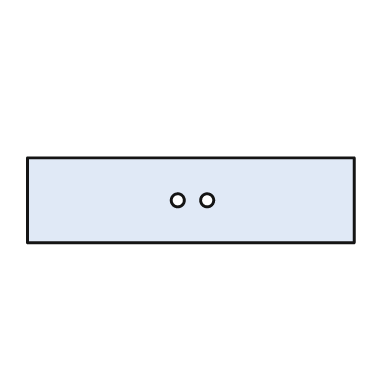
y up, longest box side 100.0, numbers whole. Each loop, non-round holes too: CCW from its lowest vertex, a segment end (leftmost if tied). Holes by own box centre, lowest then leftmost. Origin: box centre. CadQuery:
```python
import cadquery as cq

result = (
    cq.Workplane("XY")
    .moveTo(-50.0, -13.0)
    .lineTo(50.0, -13.0)
    .lineTo(50.0, 13.0)
    .lineTo(-50.0, 13.0)
    .close()
    .moveTo(-4.0, 0.0)
    .circle(2.0)
    .moveTo(5.0, 0.0)
    .circle(2.0)
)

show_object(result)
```